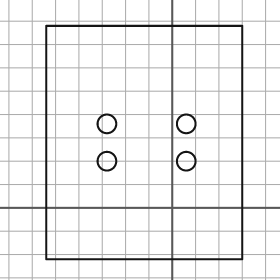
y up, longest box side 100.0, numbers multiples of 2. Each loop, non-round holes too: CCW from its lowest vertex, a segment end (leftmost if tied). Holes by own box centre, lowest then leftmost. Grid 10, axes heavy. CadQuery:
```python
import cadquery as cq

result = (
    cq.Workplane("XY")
    .moveTo(-54.0, -22.0)
    .lineTo(30.0, -22.0)
    .lineTo(30.0, 78.0)
    .lineTo(-54.0, 78.0)
    .close()
    .moveTo(-28.0, 20.0)
    .circle(4.0)
    .moveTo(6.0, 20.0)
    .circle(4.0)
    .moveTo(-28.0, 36.0)
    .circle(4.0)
    .moveTo(6.0, 36.0)
    .circle(4.0)
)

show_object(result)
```